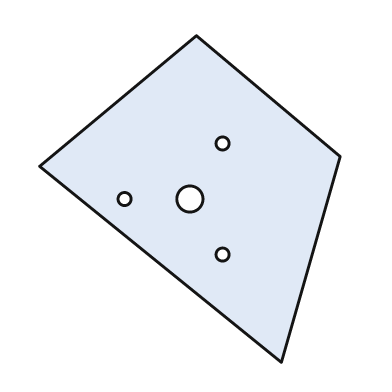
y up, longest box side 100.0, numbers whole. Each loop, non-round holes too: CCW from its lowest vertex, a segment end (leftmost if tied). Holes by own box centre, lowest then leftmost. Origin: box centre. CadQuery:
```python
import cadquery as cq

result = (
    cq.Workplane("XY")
    .moveTo(28.0, -50.0)
    .lineTo(46.0, 13.0)
    .lineTo(2.0, 50.0)
    .lineTo(-46.0, 10.0)
    .close()
    .moveTo(10.0, -17.0)
    .circle(2.0)
    .moveTo(-20.0, 0.0)
    .circle(2.0)
    .moveTo(0.0, 0.0)
    .circle(4.0)
    .moveTo(10.0, 17.0)
    .circle(2.0)
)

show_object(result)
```